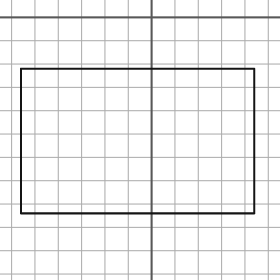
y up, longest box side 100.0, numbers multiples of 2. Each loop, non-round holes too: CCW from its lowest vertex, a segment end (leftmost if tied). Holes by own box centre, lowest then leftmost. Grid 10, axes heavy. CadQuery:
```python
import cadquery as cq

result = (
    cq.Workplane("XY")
    .moveTo(-56.0, -84.0)
    .lineTo(44.0, -84.0)
    .lineTo(44.0, -22.0)
    .lineTo(-56.0, -22.0)
    .close()
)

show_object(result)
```